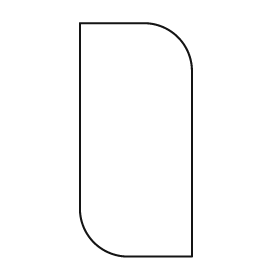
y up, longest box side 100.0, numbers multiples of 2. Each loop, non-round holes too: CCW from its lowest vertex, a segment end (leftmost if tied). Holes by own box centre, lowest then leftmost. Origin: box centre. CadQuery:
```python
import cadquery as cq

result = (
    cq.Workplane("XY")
    .moveTo(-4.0, -50.0)
    .lineTo(24.0, -50.0)
    .lineTo(24.0, 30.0)
    .threePointArc((18.0, 44.0), (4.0, 50.0))
    .lineTo(-24.0, 50.0)
    .lineTo(-24.0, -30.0)
    .threePointArc((-18.0, -44.0), (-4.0, -50.0))
    .close()
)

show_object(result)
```